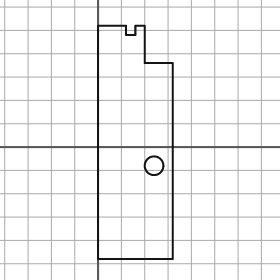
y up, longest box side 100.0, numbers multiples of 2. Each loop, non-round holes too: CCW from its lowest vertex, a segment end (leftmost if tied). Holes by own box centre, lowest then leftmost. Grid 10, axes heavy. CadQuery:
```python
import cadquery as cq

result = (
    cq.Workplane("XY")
    .moveTo(0.0, -48.0)
    .lineTo(32.0, -48.0)
    .lineTo(32.0, 36.0)
    .lineTo(20.0, 36.0)
    .lineTo(20.0, 52.0)
    .lineTo(16.0, 52.0)
    .lineTo(16.0, 48.0)
    .lineTo(12.0, 48.0)
    .lineTo(12.0, 52.0)
    .lineTo(0.0, 52.0)
    .close()
    .moveTo(24.0, -8.0)
    .circle(4.0)
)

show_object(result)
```